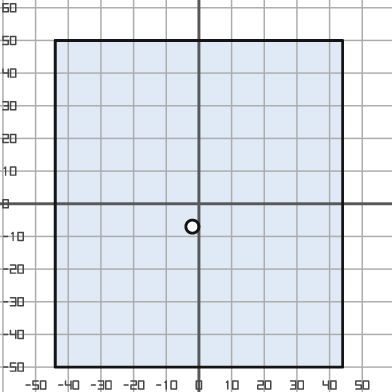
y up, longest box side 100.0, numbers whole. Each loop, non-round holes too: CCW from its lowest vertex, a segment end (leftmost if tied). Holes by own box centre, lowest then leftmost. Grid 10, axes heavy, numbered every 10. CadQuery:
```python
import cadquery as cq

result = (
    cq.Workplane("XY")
    .moveTo(-44.0, -50.0)
    .lineTo(44.0, -50.0)
    .lineTo(44.0, 50.0)
    .lineTo(-44.0, 50.0)
    .close()
    .moveTo(-2.0, -7.0)
    .circle(2.0)
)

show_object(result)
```